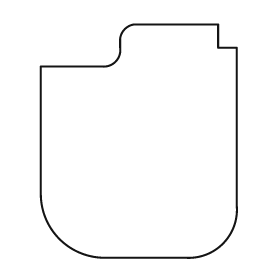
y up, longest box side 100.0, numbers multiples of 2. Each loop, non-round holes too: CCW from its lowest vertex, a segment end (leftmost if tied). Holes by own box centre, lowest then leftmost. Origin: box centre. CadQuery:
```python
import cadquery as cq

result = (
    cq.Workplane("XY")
    .moveTo(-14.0, -50.0)
    .lineTo(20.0, -50.0)
    .threePointArc((36.0, -44.0), (42.0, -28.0))
    .lineTo(42.0, 40.0)
    .lineTo(34.0, 40.0)
    .lineTo(34.0, 50.0)
    .lineTo(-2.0, 50.0)
    .threePointArc((-6.0, 48.0), (-8.0, 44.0))
    .lineTo(-8.0, 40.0)
    .threePointArc((-10.0, 34.0), (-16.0, 32.0))
    .lineTo(-42.0, 32.0)
    .lineTo(-42.0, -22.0)
    .threePointArc((-34.0, -42.0), (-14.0, -50.0))
    .close()
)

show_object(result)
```